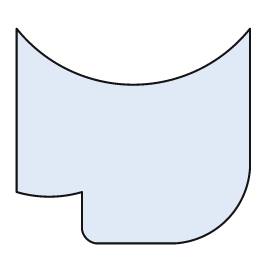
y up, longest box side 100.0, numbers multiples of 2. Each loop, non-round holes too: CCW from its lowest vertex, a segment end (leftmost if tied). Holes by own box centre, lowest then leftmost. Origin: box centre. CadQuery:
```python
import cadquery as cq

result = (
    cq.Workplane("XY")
    .moveTo(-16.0, -46.0)
    .lineTo(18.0, -46.0)
    .threePointArc((40.0, -36.0), (50.0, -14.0))
    .lineTo(50.0, 46.0)
    .threePointArc((0.0, 22.0), (-50.0, 46.0))
    .lineTo(-50.0, -24.0)
    .threePointArc((-36.0, -26.0), (-22.0, -24.0))
    .lineTo(-22.0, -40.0)
    .threePointArc((-20.0, -44.0), (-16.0, -46.0))
    .close()
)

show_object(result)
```